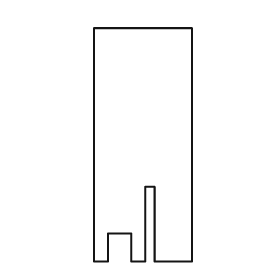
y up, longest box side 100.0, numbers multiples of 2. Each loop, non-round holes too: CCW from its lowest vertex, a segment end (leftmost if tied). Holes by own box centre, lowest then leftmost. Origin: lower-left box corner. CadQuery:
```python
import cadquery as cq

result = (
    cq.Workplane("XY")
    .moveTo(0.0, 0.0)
    .lineTo(6.0, 0.0)
    .lineTo(6.0, 12.0)
    .lineTo(16.0, 12.0)
    .lineTo(16.0, 0.0)
    .lineTo(22.0, 0.0)
    .lineTo(22.0, 32.0)
    .lineTo(26.0, 32.0)
    .lineTo(26.0, 0.0)
    .lineTo(42.0, 0.0)
    .lineTo(42.0, 100.0)
    .lineTo(0.0, 100.0)
    .close()
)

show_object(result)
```